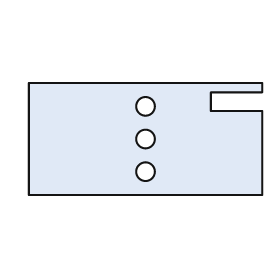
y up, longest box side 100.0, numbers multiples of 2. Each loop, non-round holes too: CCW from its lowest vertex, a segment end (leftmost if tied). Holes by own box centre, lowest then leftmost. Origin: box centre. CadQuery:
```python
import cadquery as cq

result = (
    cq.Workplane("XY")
    .moveTo(-50.0, -24.0)
    .lineTo(50.0, -24.0)
    .lineTo(50.0, 12.0)
    .lineTo(28.0, 12.0)
    .lineTo(28.0, 20.0)
    .lineTo(50.0, 20.0)
    .lineTo(50.0, 24.0)
    .lineTo(-50.0, 24.0)
    .close()
    .moveTo(0.0, -14.0)
    .circle(4.0)
    .moveTo(0.0, 0.0)
    .circle(4.0)
    .moveTo(0.0, 14.0)
    .circle(4.0)
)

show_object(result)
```